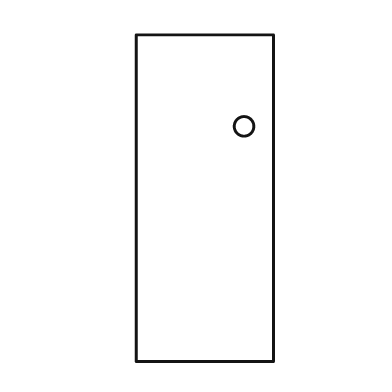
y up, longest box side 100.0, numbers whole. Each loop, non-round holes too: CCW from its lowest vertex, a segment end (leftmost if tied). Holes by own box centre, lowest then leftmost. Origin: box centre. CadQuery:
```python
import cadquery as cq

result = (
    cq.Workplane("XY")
    .moveTo(-21.0, -50.0)
    .lineTo(21.0, -50.0)
    .lineTo(21.0, 50.0)
    .lineTo(-21.0, 50.0)
    .close()
    .moveTo(12.0, 22.0)
    .circle(3.0)
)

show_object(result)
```